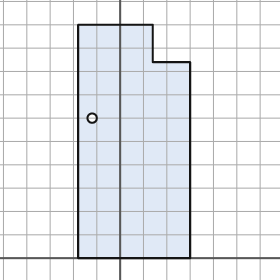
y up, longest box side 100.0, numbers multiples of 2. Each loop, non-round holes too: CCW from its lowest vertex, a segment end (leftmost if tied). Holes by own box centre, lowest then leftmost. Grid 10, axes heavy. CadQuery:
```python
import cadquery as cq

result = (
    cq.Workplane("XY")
    .moveTo(-18.0, 0.0)
    .lineTo(30.0, 0.0)
    .lineTo(30.0, 84.0)
    .lineTo(14.0, 84.0)
    .lineTo(14.0, 100.0)
    .lineTo(-18.0, 100.0)
    .close()
    .moveTo(-12.0, 60.0)
    .circle(2.0)
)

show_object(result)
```